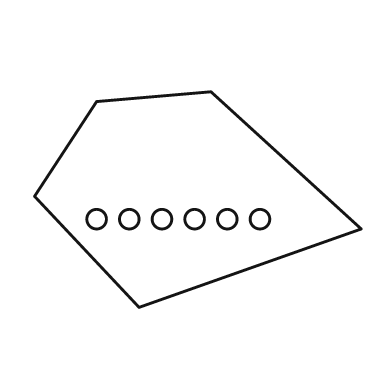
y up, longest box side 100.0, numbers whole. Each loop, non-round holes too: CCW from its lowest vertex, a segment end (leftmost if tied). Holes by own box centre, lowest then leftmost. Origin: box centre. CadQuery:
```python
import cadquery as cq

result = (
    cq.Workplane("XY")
    .moveTo(-18.0, -33.0)
    .lineTo(50.0, -9.0)
    .lineTo(4.0, 33.0)
    .lineTo(-31.0, 30.0)
    .lineTo(-50.0, 1.0)
    .close()
    .moveTo(-31.0, -6.0)
    .circle(3.0)
    .moveTo(-21.0, -6.0)
    .circle(3.0)
    .moveTo(-11.0, -6.0)
    .circle(3.0)
    .moveTo(-1.0, -6.0)
    .circle(3.0)
    .moveTo(9.0, -6.0)
    .circle(3.0)
    .moveTo(19.0, -6.0)
    .circle(3.0)
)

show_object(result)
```